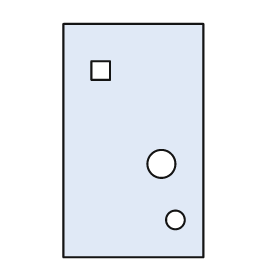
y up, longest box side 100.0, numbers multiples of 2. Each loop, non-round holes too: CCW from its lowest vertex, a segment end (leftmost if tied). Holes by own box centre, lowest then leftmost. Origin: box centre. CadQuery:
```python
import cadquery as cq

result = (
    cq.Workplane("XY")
    .moveTo(-30.0, -50.0)
    .lineTo(30.0, -50.0)
    .lineTo(30.0, 50.0)
    .lineTo(-30.0, 50.0)
    .close()
    .moveTo(18.0, -34.0)
    .circle(4.0)
    .moveTo(12.0, -10.0)
    .circle(6.0)
    .moveTo(-18.0, 26.0)
    .lineTo(-10.0, 26.0)
    .lineTo(-10.0, 34.0)
    .lineTo(-18.0, 34.0)
    .close()
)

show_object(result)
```